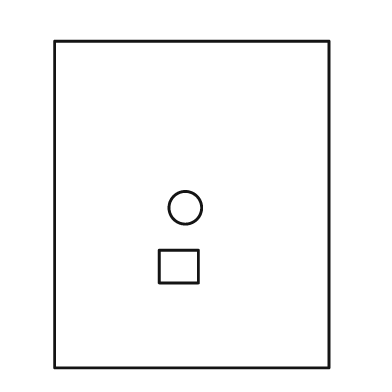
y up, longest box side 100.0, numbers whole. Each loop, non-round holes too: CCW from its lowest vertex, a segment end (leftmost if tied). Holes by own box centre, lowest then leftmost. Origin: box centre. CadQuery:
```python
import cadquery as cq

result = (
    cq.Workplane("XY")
    .moveTo(-42.0, -50.0)
    .lineTo(42.0, -50.0)
    .lineTo(42.0, 50.0)
    .lineTo(-42.0, 50.0)
    .close()
    .moveTo(-10.0, -24.0)
    .lineTo(2.0, -24.0)
    .lineTo(2.0, -14.0)
    .lineTo(-10.0, -14.0)
    .close()
    .moveTo(-2.0, -1.0)
    .circle(5.0)
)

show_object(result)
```